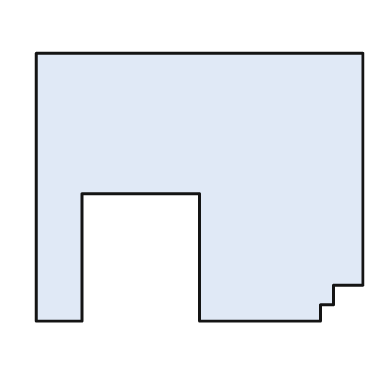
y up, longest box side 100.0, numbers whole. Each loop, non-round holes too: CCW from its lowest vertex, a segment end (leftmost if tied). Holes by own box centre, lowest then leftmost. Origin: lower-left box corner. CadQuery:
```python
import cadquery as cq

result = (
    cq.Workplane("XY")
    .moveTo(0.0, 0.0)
    .lineTo(14.0, 0.0)
    .lineTo(14.0, 39.0)
    .lineTo(50.0, 39.0)
    .lineTo(50.0, 0.0)
    .lineTo(87.0, 0.0)
    .lineTo(87.0, 5.0)
    .lineTo(91.0, 5.0)
    .lineTo(91.0, 11.0)
    .lineTo(100.0, 11.0)
    .lineTo(100.0, 82.0)
    .lineTo(0.0, 82.0)
    .close()
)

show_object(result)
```